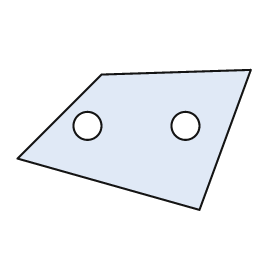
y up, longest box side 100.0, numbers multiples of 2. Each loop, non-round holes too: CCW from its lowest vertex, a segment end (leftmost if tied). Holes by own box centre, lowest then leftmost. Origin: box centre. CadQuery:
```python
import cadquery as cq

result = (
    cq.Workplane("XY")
    .moveTo(28.0, -30.0)
    .lineTo(50.0, 30.0)
    .lineTo(-14.0, 28.0)
    .lineTo(-50.0, -8.0)
    .close()
    .moveTo(-20.0, 6.0)
    .circle(6.0)
    .moveTo(22.0, 6.0)
    .circle(6.0)
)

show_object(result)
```